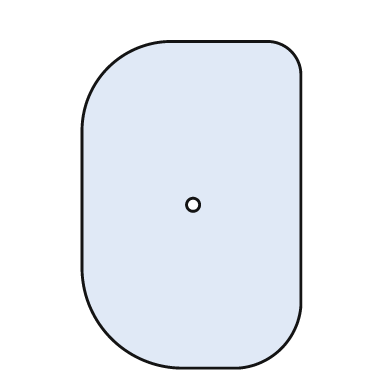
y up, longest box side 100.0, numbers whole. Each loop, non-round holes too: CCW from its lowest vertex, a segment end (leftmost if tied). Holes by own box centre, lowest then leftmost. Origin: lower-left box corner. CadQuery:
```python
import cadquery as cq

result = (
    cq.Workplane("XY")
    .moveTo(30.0, 0.0)
    .lineTo(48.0, 0.0)
    .threePointArc((61.0, 6.0), (67.0, 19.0))
    .lineTo(67.0, 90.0)
    .threePointArc((64.0, 97.0), (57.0, 100.0))
    .lineTo(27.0, 100.0)
    .threePointArc((8.0, 92.0), (0.0, 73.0))
    .lineTo(0.0, 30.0)
    .threePointArc((9.0, 9.0), (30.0, 0.0))
    .close()
    .moveTo(34.0, 50.0)
    .circle(2.0)
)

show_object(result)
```